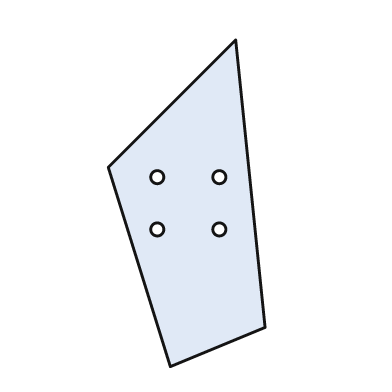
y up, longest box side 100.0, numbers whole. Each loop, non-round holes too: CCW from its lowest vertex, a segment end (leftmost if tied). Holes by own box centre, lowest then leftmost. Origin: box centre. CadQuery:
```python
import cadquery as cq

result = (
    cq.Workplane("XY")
    .moveTo(-5.0, -50.0)
    .lineTo(24.0, -38.0)
    .lineTo(15.0, 50.0)
    .lineTo(-24.0, 11.0)
    .close()
    .moveTo(-9.0, -8.0)
    .circle(2.0)
    .moveTo(10.0, -8.0)
    .circle(2.0)
    .moveTo(-9.0, 8.0)
    .circle(2.0)
    .moveTo(10.0, 8.0)
    .circle(2.0)
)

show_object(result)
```